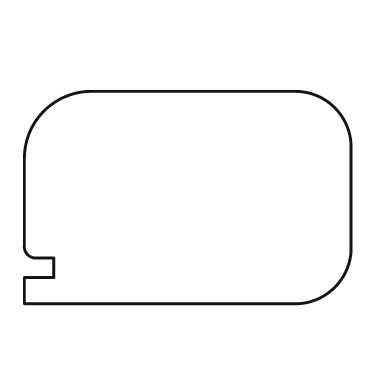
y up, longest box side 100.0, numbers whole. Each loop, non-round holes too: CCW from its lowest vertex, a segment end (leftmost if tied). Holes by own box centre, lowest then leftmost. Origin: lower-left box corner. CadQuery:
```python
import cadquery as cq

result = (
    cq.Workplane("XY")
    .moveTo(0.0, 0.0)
    .lineTo(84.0, 0.0)
    .threePointArc((95.0, 5.0), (100.0, 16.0))
    .lineTo(100.0, 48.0)
    .threePointArc((95.0, 60.0), (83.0, 65.0))
    .lineTo(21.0, 65.0)
    .threePointArc((6.0, 59.0), (0.0, 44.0))
    .lineTo(0.0, 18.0)
    .threePointArc((1.0, 15.0), (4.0, 14.0))
    .lineTo(9.0, 14.0)
    .lineTo(9.0, 8.0)
    .lineTo(0.0, 8.0)
    .close()
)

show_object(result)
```